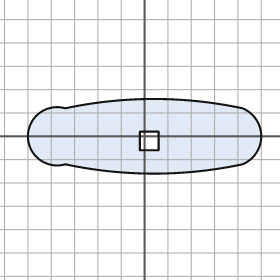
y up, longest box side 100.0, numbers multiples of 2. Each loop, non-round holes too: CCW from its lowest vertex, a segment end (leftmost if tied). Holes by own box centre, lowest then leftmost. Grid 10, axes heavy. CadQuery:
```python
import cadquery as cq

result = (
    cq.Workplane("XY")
    .moveTo(-34.0, -12.0)
    .threePointArc((4.0, -16.0), (42.0, -12.0))
    .threePointArc((50.0, 0.0), (42.0, 12.0))
    .threePointArc((4.0, 16.0), (-34.0, 12.0))
    .threePointArc((-50.0, 0.0), (-34.0, -12.0))
    .close()
    .moveTo(-2.0, -6.0)
    .lineTo(6.0, -6.0)
    .lineTo(6.0, 2.0)
    .lineTo(-2.0, 2.0)
    .close()
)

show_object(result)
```